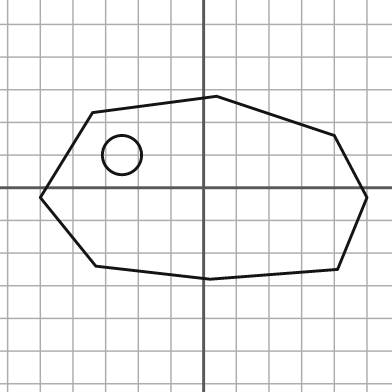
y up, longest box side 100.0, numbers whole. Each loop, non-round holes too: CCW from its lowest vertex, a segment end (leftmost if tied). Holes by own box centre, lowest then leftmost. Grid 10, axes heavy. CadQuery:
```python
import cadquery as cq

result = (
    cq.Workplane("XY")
    .moveTo(2.0, -28.0)
    .lineTo(41.0, -25.0)
    .lineTo(50.0, -3.0)
    .lineTo(40.0, 16.0)
    .lineTo(4.0, 28.0)
    .lineTo(-34.0, 23.0)
    .lineTo(-50.0, -3.0)
    .lineTo(-33.0, -24.0)
    .close()
    .moveTo(-25.0, 10.0)
    .circle(6.0)
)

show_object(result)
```